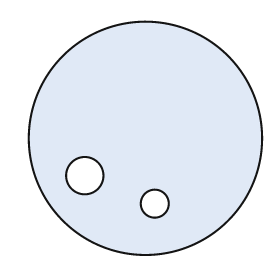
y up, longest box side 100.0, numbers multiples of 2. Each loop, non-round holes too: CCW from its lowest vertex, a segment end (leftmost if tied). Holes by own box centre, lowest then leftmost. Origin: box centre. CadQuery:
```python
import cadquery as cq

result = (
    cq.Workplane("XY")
    .moveTo(0.0, 0.0)
    .circle(50.0)
    .moveTo(4.0, -28.0)
    .circle(6.0)
    .moveTo(-26.0, -16.0)
    .circle(8.0)
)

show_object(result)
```